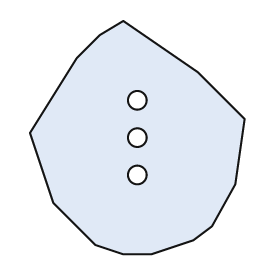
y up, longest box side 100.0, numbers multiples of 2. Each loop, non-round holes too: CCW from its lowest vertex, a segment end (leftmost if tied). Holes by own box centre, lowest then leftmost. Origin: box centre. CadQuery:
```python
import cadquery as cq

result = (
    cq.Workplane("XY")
    .moveTo(-6.0, -50.0)
    .lineTo(6.0, -50.0)
    .lineTo(24.0, -44.0)
    .lineTo(32.0, -38.0)
    .lineTo(42.0, -20.0)
    .lineTo(46.0, 8.0)
    .lineTo(26.0, 28.0)
    .lineTo(-6.0, 50.0)
    .lineTo(-16.0, 44.0)
    .lineTo(-26.0, 34.0)
    .lineTo(-46.0, 2.0)
    .lineTo(-36.0, -28.0)
    .lineTo(-18.0, -46.0)
    .close()
    .moveTo(0.0, -16.0)
    .circle(4.0)
    .moveTo(0.0, 0.0)
    .circle(4.0)
    .moveTo(0.0, 16.0)
    .circle(4.0)
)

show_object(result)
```